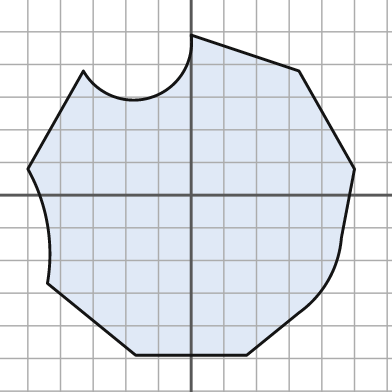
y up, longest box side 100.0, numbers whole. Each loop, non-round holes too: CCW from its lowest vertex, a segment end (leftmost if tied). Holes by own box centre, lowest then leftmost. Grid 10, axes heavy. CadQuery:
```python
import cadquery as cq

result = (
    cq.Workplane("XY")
    .moveTo(-17.0, -49.0)
    .lineTo(17.0, -49.0)
    .lineTo(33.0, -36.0)
    .threePointArc((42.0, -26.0), (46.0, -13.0))
    .lineTo(50.0, 8.0)
    .lineTo(33.0, 38.0)
    .lineTo(0.0, 49.0)
    .threePointArc((-12.0, 30.0), (-33.0, 38.0))
    .lineTo(-50.0, 8.0)
    .threePointArc((-44.0, -9.0), (-44.0, -27.0))
    .close()
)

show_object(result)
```